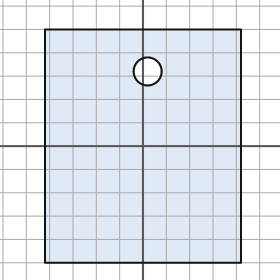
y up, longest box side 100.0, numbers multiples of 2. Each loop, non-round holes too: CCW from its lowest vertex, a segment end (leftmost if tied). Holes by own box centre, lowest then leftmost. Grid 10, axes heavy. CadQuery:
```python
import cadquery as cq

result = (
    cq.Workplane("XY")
    .moveTo(-42.0, -50.0)
    .lineTo(42.0, -50.0)
    .lineTo(42.0, 50.0)
    .lineTo(-42.0, 50.0)
    .close()
    .moveTo(2.0, 32.0)
    .circle(6.0)
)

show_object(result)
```